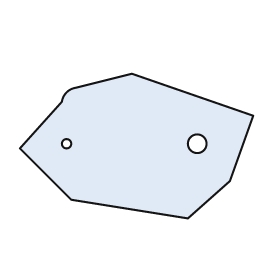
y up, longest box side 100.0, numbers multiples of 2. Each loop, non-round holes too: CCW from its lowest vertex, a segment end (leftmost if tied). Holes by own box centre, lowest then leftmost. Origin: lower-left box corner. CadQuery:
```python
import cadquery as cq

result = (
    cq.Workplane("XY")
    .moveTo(72.0, 0.0)
    .lineTo(90.0, 16.0)
    .lineTo(100.0, 44.0)
    .lineTo(48.0, 62.0)
    .lineTo(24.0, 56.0)
    .threePointArc((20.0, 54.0), (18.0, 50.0))
    .lineTo(0.0, 30.0)
    .lineTo(22.0, 8.0)
    .close()
    .moveTo(20.0, 32.0)
    .circle(2.0)
    .moveTo(76.0, 32.0)
    .circle(4.0)
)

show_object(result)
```